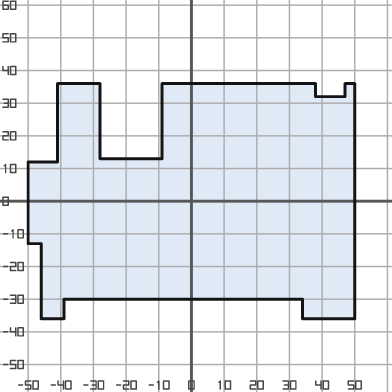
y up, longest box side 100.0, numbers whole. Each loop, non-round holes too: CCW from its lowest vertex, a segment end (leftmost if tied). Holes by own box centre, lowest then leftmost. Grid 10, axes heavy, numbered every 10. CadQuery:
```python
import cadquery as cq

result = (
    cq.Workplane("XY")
    .moveTo(-46.0, -36.0)
    .lineTo(-39.0, -36.0)
    .lineTo(-39.0, -30.0)
    .lineTo(34.0, -30.0)
    .lineTo(34.0, -36.0)
    .lineTo(50.0, -36.0)
    .lineTo(50.0, 36.0)
    .lineTo(47.0, 36.0)
    .lineTo(47.0, 32.0)
    .lineTo(38.0, 32.0)
    .lineTo(38.0, 36.0)
    .lineTo(-9.0, 36.0)
    .lineTo(-9.0, 13.0)
    .lineTo(-28.0, 13.0)
    .lineTo(-28.0, 36.0)
    .lineTo(-41.0, 36.0)
    .lineTo(-41.0, 12.0)
    .lineTo(-50.0, 12.0)
    .lineTo(-50.0, -13.0)
    .lineTo(-46.0, -13.0)
    .close()
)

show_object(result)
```